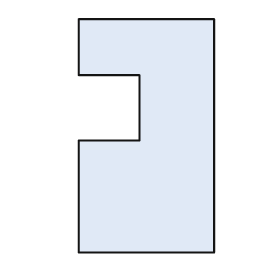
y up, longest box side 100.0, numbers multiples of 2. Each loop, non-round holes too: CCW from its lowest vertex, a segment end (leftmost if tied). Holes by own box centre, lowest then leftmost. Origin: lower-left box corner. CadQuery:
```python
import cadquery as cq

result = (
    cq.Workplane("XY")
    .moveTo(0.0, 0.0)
    .lineTo(58.0, 0.0)
    .lineTo(58.0, 100.0)
    .lineTo(0.0, 100.0)
    .lineTo(0.0, 76.0)
    .lineTo(26.0, 76.0)
    .lineTo(26.0, 48.0)
    .lineTo(0.0, 48.0)
    .close()
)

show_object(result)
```